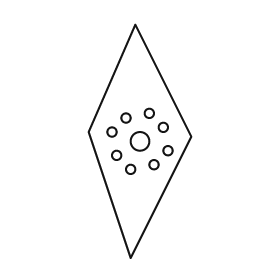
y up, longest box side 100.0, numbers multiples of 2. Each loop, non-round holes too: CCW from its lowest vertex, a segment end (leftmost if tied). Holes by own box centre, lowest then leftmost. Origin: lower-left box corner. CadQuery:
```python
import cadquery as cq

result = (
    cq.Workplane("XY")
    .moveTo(18.0, 0.0)
    .lineTo(44.0, 52.0)
    .lineTo(20.0, 100.0)
    .lineTo(0.0, 54.0)
    .close()
    .moveTo(18.0, 38.0)
    .circle(2.0)
    .moveTo(28.0, 40.0)
    .circle(2.0)
    .moveTo(12.0, 44.0)
    .circle(2.0)
    .moveTo(34.0, 46.0)
    .circle(2.0)
    .moveTo(22.0, 50.0)
    .circle(4.0)
    .moveTo(10.0, 54.0)
    .circle(2.0)
    .moveTo(32.0, 56.0)
    .circle(2.0)
    .moveTo(16.0, 60.0)
    .circle(2.0)
    .moveTo(26.0, 62.0)
    .circle(2.0)
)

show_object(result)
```